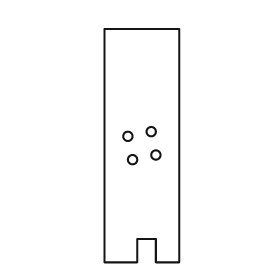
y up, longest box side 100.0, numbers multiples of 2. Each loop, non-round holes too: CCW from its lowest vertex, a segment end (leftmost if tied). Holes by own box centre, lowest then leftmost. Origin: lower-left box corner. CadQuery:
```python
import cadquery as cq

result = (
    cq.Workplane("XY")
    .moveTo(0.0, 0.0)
    .lineTo(14.0, 0.0)
    .lineTo(14.0, 10.0)
    .lineTo(22.0, 10.0)
    .lineTo(22.0, 0.0)
    .lineTo(32.0, 0.0)
    .lineTo(32.0, 100.0)
    .lineTo(0.0, 100.0)
    .close()
    .moveTo(12.0, 44.0)
    .circle(2.0)
    .moveTo(22.0, 46.0)
    .circle(2.0)
    .moveTo(10.0, 54.0)
    .circle(2.0)
    .moveTo(20.0, 56.0)
    .circle(2.0)
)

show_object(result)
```